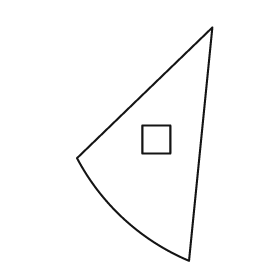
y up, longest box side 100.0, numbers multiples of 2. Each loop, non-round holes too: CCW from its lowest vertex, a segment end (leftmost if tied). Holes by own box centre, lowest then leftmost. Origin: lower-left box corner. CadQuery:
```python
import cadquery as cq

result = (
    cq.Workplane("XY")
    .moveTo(48.0, 0.0)
    .lineTo(58.0, 100.0)
    .lineTo(0.0, 44.0)
    .threePointArc((20.0, 18.0), (48.0, 0.0))
    .close()
    .moveTo(28.0, 46.0)
    .lineTo(40.0, 46.0)
    .lineTo(40.0, 58.0)
    .lineTo(28.0, 58.0)
    .close()
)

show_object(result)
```